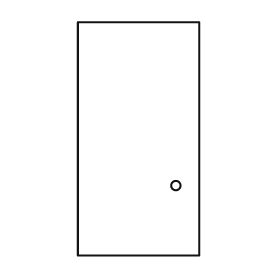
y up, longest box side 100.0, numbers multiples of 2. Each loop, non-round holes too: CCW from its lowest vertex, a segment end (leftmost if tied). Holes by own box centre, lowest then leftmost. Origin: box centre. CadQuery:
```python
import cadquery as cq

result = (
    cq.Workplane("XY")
    .moveTo(-26.0, -50.0)
    .lineTo(26.0, -50.0)
    .lineTo(26.0, 50.0)
    .lineTo(-26.0, 50.0)
    .close()
    .moveTo(16.0, -20.0)
    .circle(2.0)
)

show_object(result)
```